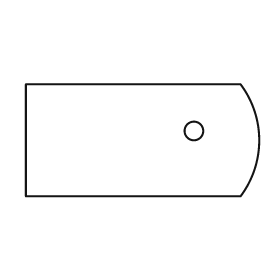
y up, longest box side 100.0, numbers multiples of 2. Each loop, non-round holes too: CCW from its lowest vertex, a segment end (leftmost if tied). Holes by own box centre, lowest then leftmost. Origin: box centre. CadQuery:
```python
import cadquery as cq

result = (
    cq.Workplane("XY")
    .moveTo(-50.0, -24.0)
    .lineTo(42.0, -24.0)
    .threePointArc((50.0, 0.0), (42.0, 24.0))
    .lineTo(-50.0, 24.0)
    .close()
    .moveTo(22.0, 4.0)
    .circle(4.0)
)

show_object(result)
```